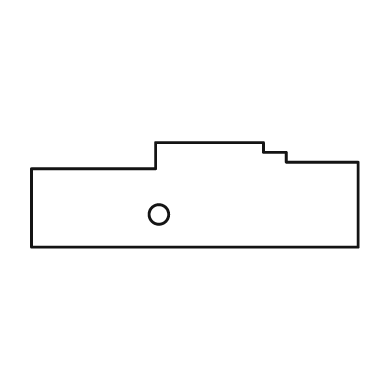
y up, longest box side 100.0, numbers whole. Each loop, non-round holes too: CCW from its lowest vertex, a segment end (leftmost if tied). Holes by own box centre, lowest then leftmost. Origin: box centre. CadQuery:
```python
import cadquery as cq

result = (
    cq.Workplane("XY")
    .moveTo(-50.0, -16.0)
    .lineTo(50.0, -16.0)
    .lineTo(50.0, 10.0)
    .lineTo(28.0, 10.0)
    .lineTo(28.0, 13.0)
    .lineTo(21.0, 13.0)
    .lineTo(21.0, 16.0)
    .lineTo(-12.0, 16.0)
    .lineTo(-12.0, 8.0)
    .lineTo(-50.0, 8.0)
    .close()
    .moveTo(-11.0, -6.0)
    .circle(3.0)
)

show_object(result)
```